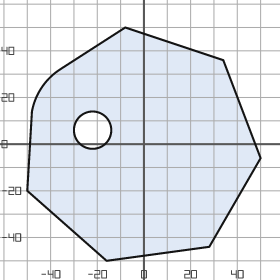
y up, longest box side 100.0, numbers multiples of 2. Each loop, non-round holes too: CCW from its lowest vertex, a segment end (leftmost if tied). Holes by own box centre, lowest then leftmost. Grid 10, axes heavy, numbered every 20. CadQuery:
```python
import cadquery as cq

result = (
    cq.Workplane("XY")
    .moveTo(-16.0, -50.0)
    .lineTo(28.0, -44.0)
    .lineTo(50.0, -6.0)
    .lineTo(34.0, 36.0)
    .lineTo(-8.0, 50.0)
    .lineTo(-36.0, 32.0)
    .threePointArc((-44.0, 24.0), (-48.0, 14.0))
    .lineTo(-50.0, -20.0)
    .close()
    .moveTo(-22.0, 6.0)
    .circle(8.0)
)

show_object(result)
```